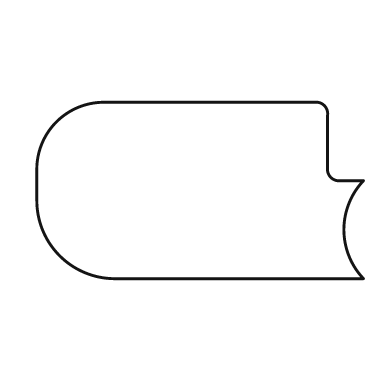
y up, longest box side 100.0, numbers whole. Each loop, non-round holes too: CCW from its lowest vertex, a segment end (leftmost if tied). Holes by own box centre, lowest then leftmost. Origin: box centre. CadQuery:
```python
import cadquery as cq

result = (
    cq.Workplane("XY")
    .moveTo(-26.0, -27.0)
    .lineTo(50.0, -27.0)
    .threePointArc((44.0, -12.0), (50.0, 3.0))
    .lineTo(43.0, 3.0)
    .threePointArc((40.0, 4.0), (39.0, 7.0))
    .lineTo(39.0, 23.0)
    .threePointArc((38.0, 26.0), (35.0, 27.0))
    .lineTo(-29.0, 27.0)
    .threePointArc((-44.0, 21.0), (-50.0, 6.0))
    .lineTo(-50.0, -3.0)
    .threePointArc((-43.0, -20.0), (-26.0, -27.0))
    .close()
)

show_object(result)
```